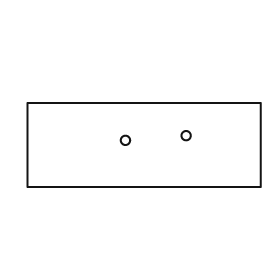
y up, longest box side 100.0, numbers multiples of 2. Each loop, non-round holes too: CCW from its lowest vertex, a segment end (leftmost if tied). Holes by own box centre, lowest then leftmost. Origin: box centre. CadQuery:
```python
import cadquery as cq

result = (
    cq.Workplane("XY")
    .moveTo(-50.0, -18.0)
    .lineTo(50.0, -18.0)
    .lineTo(50.0, 18.0)
    .lineTo(-50.0, 18.0)
    .close()
    .moveTo(-8.0, 2.0)
    .circle(2.0)
    .moveTo(18.0, 4.0)
    .circle(2.0)
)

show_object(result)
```